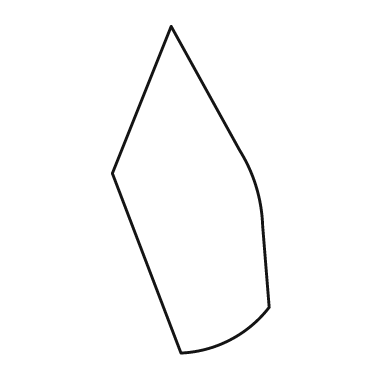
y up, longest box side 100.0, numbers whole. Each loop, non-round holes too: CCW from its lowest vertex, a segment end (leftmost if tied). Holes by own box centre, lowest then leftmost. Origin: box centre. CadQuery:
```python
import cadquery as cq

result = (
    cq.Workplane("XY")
    .moveTo(-3.0, -50.0)
    .threePointArc((12.0, -46.0), (24.0, -36.0))
    .lineTo(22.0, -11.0)
    .threePointArc((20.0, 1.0), (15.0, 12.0))
    .lineTo(-6.0, 50.0)
    .lineTo(-24.0, 5.0)
    .close()
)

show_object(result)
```